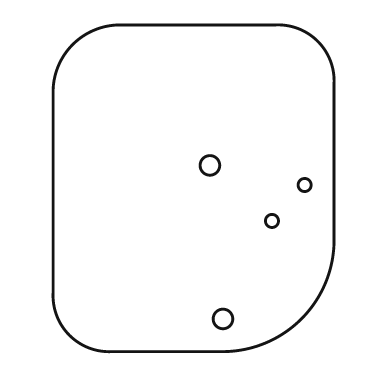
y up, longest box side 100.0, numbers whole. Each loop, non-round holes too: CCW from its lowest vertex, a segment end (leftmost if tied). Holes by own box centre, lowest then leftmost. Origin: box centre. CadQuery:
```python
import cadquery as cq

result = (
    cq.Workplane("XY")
    .moveTo(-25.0, -50.0)
    .lineTo(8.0, -50.0)
    .threePointArc((33.0, -40.0), (43.0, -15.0))
    .lineTo(43.0, 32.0)
    .threePointArc((38.0, 45.0), (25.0, 50.0))
    .lineTo(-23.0, 50.0)
    .threePointArc((-37.0, 44.0), (-43.0, 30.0))
    .lineTo(-43.0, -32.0)
    .threePointArc((-38.0, -45.0), (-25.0, -50.0))
    .close()
    .moveTo(9.0, -40.0)
    .circle(3.0)
    .moveTo(24.0, -10.0)
    .circle(2.0)
    .moveTo(34.0, 1.0)
    .circle(2.0)
    .moveTo(5.0, 7.0)
    .circle(3.0)
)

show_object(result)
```